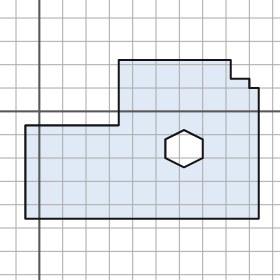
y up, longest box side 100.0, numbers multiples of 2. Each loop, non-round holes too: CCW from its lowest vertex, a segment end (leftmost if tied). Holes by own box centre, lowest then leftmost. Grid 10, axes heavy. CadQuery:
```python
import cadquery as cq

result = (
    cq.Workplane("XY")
    .moveTo(-6.0, -46.0)
    .lineTo(94.0, -46.0)
    .lineTo(94.0, 10.0)
    .lineTo(90.0, 10.0)
    .lineTo(90.0, 14.0)
    .lineTo(82.0, 14.0)
    .lineTo(82.0, 22.0)
    .lineTo(34.0, 22.0)
    .lineTo(34.0, -6.0)
    .lineTo(-6.0, -6.0)
    .close()
    .moveTo(62.0, -24.0)
    .lineTo(70.0, -20.0)
    .lineTo(70.0, -12.0)
    .lineTo(62.0, -8.0)
    .lineTo(54.0, -12.0)
    .lineTo(54.0, -20.0)
    .close()
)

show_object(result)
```